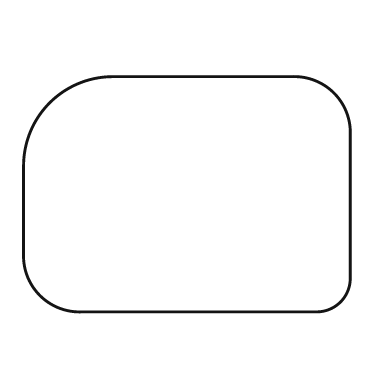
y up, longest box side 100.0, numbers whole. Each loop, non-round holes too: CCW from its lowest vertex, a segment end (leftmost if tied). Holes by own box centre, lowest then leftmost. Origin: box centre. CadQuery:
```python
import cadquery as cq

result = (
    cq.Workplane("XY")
    .moveTo(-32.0, -36.0)
    .lineTo(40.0, -36.0)
    .threePointArc((47.0, -33.0), (50.0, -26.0))
    .lineTo(50.0, 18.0)
    .threePointArc((45.0, 31.0), (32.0, 36.0))
    .lineTo(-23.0, 36.0)
    .threePointArc((-42.0, 28.0), (-50.0, 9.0))
    .lineTo(-50.0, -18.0)
    .threePointArc((-45.0, -31.0), (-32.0, -36.0))
    .close()
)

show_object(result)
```